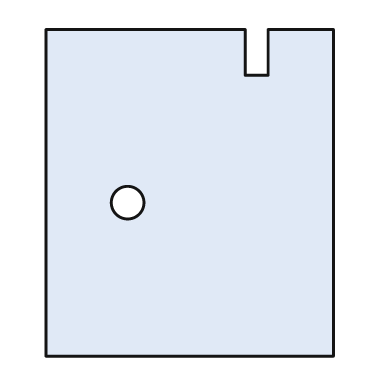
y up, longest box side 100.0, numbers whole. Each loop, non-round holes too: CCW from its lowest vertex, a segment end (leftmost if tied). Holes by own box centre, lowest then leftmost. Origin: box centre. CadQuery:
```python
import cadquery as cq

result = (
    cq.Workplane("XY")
    .moveTo(-44.0, -50.0)
    .lineTo(44.0, -50.0)
    .lineTo(44.0, 50.0)
    .lineTo(24.0, 50.0)
    .lineTo(24.0, 36.0)
    .lineTo(17.0, 36.0)
    .lineTo(17.0, 50.0)
    .lineTo(-44.0, 50.0)
    .close()
    .moveTo(-19.0, -3.0)
    .circle(5.0)
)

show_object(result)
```